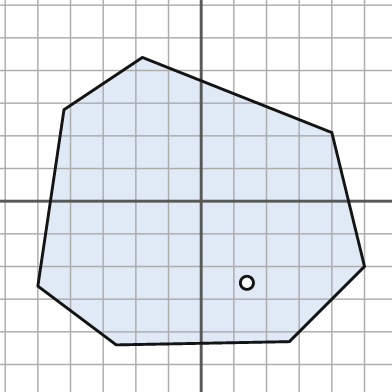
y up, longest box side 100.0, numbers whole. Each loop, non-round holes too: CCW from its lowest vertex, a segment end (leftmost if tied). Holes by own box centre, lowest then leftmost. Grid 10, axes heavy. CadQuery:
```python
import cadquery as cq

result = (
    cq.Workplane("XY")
    .moveTo(-26.0, -44.0)
    .lineTo(27.0, -43.0)
    .lineTo(50.0, -20.0)
    .lineTo(40.0, 21.0)
    .lineTo(-18.0, 44.0)
    .lineTo(-42.0, 28.0)
    .lineTo(-50.0, -26.0)
    .close()
    .moveTo(14.0, -25.0)
    .circle(2.0)
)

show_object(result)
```